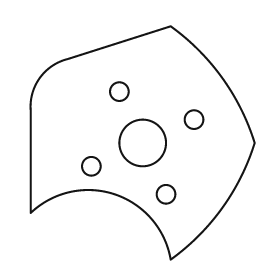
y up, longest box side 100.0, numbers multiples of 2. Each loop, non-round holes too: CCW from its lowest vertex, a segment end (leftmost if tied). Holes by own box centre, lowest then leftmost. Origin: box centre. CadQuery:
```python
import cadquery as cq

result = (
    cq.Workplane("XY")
    .moveTo(12.0, -50.0)
    .threePointArc((34.0, -28.0), (48.0, 0.0))
    .threePointArc((34.0, 28.0), (12.0, 50.0))
    .lineTo(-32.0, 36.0)
    .threePointArc((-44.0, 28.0), (-48.0, 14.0))
    .lineTo(-48.0, -30.0)
    .threePointArc((-12.0, -22.0), (12.0, -50.0))
    .close()
    .moveTo(10.0, -22.0)
    .circle(4.0)
    .moveTo(-22.0, -10.0)
    .circle(4.0)
    .moveTo(0.0, 0.0)
    .circle(10.0)
    .moveTo(22.0, 10.0)
    .circle(4.0)
    .moveTo(-10.0, 22.0)
    .circle(4.0)
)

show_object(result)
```